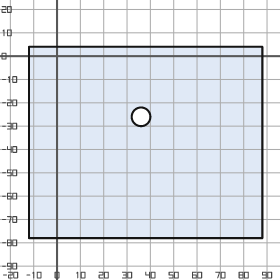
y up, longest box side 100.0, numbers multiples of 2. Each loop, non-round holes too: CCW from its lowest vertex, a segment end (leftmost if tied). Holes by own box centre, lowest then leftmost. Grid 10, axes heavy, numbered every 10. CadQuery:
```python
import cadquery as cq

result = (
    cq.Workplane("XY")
    .moveTo(-12.0, -78.0)
    .lineTo(88.0, -78.0)
    .lineTo(88.0, 4.0)
    .lineTo(-12.0, 4.0)
    .close()
    .moveTo(36.0, -26.0)
    .circle(4.0)
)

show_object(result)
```